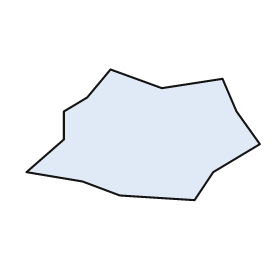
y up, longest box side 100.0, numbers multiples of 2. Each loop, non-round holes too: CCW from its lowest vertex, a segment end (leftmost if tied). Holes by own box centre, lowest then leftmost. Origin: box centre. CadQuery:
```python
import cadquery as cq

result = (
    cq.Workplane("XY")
    .moveTo(22.0, -28.0)
    .lineTo(30.0, -16.0)
    .lineTo(50.0, -4.0)
    .lineTo(40.0, 10.0)
    .lineTo(34.0, 24.0)
    .lineTo(8.0, 20.0)
    .lineTo(-14.0, 28.0)
    .lineTo(-24.0, 16.0)
    .lineTo(-34.0, 10.0)
    .lineTo(-34.0, -2.0)
    .lineTo(-50.0, -16.0)
    .lineTo(-26.0, -20.0)
    .lineTo(-10.0, -26.0)
    .close()
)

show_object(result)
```